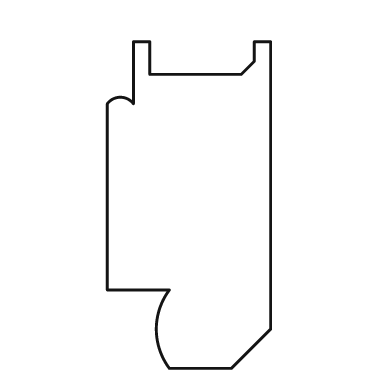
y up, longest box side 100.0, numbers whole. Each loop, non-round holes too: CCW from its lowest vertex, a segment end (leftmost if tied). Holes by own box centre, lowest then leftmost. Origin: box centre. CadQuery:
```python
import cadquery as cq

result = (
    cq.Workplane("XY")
    .moveTo(-6.0, -50.0)
    .lineTo(13.0, -50.0)
    .lineTo(25.0, -38.0)
    .lineTo(25.0, 50.0)
    .lineTo(20.0, 50.0)
    .lineTo(20.0, 44.0)
    .lineTo(16.0, 40.0)
    .lineTo(-12.0, 40.0)
    .lineTo(-12.0, 50.0)
    .lineTo(-17.0, 50.0)
    .lineTo(-17.0, 31.0)
    .threePointArc((-21.0, 33.0), (-25.0, 31.0))
    .lineTo(-25.0, -26.0)
    .lineTo(-6.0, -26.0)
    .threePointArc((-10.0, -38.0), (-6.0, -50.0))
    .close()
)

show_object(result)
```